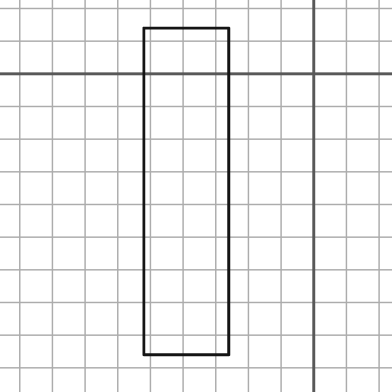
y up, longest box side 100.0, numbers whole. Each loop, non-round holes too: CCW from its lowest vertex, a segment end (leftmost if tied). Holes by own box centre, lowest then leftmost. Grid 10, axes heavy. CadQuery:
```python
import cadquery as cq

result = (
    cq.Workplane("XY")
    .moveTo(-52.0, -86.0)
    .lineTo(-26.0, -86.0)
    .lineTo(-26.0, 14.0)
    .lineTo(-52.0, 14.0)
    .close()
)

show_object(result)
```